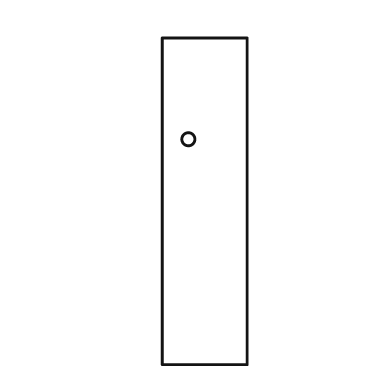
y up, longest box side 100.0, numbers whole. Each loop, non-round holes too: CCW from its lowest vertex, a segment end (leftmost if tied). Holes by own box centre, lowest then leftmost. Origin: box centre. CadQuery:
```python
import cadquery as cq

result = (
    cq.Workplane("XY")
    .moveTo(-13.0, -50.0)
    .lineTo(13.0, -50.0)
    .lineTo(13.0, 50.0)
    .lineTo(-13.0, 50.0)
    .close()
    .moveTo(-5.0, 19.0)
    .circle(2.0)
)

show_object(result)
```